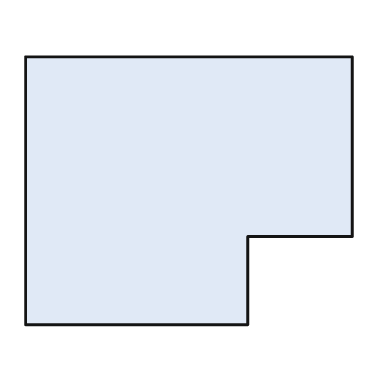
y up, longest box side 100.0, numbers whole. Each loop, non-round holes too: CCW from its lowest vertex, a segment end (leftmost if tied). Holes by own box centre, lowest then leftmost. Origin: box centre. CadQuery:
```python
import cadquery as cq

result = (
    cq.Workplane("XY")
    .moveTo(-50.0, -41.0)
    .lineTo(18.0, -41.0)
    .lineTo(18.0, -14.0)
    .lineTo(50.0, -14.0)
    .lineTo(50.0, 41.0)
    .lineTo(-50.0, 41.0)
    .close()
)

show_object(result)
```